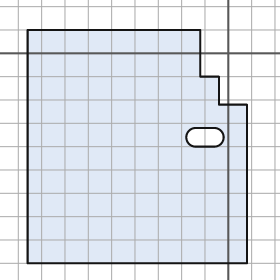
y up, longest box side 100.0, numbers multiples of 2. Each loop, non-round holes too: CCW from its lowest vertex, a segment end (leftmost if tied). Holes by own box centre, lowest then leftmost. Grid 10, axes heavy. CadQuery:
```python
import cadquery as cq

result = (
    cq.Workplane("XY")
    .moveTo(-86.0, -90.0)
    .lineTo(8.0, -90.0)
    .lineTo(8.0, -22.0)
    .lineTo(-4.0, -22.0)
    .lineTo(-4.0, -10.0)
    .lineTo(-12.0, -10.0)
    .lineTo(-12.0, 10.0)
    .lineTo(-86.0, 10.0)
    .close()
    .moveTo(-14.0, -40.0)
    .lineTo(-6.0, -40.0)
    .threePointArc((-2.0, -36.0), (-6.0, -32.0))
    .lineTo(-14.0, -32.0)
    .threePointArc((-18.0, -36.0), (-14.0, -40.0))
    .close()
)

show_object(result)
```